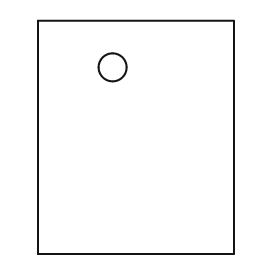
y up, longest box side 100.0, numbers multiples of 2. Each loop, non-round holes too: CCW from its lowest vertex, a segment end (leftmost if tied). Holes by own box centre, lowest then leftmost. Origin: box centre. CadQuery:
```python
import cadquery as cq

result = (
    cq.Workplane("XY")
    .moveTo(-42.0, -50.0)
    .lineTo(42.0, -50.0)
    .lineTo(42.0, 50.0)
    .lineTo(-42.0, 50.0)
    .close()
    .moveTo(-10.0, 30.0)
    .circle(6.0)
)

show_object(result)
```